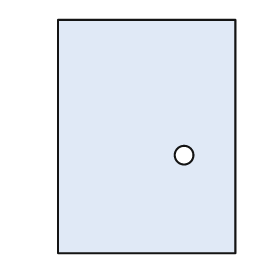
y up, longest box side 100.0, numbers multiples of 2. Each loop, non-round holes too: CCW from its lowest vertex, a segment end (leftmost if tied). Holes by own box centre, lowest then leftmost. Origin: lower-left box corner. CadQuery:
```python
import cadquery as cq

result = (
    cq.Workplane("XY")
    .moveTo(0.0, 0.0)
    .lineTo(76.0, 0.0)
    .lineTo(76.0, 100.0)
    .lineTo(0.0, 100.0)
    .close()
    .moveTo(54.0, 42.0)
    .circle(4.0)
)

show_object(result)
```